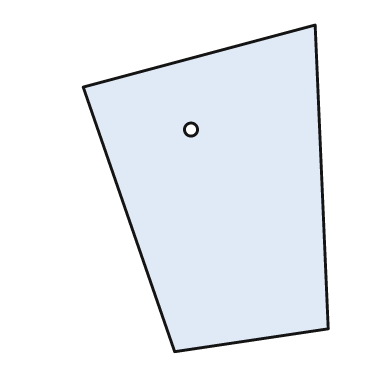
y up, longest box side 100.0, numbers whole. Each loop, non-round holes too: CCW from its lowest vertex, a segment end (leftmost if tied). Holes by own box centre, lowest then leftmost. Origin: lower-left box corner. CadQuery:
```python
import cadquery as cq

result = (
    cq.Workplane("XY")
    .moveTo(28.0, 0.0)
    .lineTo(75.0, 7.0)
    .lineTo(71.0, 100.0)
    .lineTo(0.0, 81.0)
    .close()
    .moveTo(33.0, 68.0)
    .circle(2.0)
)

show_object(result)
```